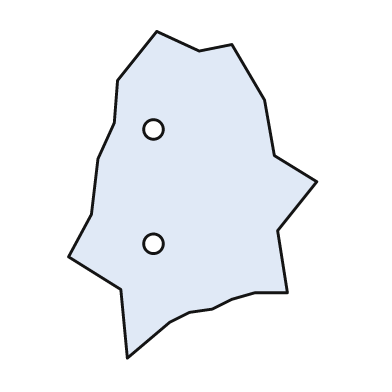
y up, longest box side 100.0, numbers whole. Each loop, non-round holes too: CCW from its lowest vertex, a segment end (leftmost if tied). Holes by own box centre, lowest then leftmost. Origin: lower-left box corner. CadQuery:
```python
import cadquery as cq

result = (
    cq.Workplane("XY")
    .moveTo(18.0, 0.0)
    .lineTo(31.0, 11.0)
    .lineTo(37.0, 14.0)
    .lineTo(44.0, 15.0)
    .lineTo(50.0, 18.0)
    .lineTo(57.0, 20.0)
    .lineTo(67.0, 20.0)
    .lineTo(64.0, 39.0)
    .lineTo(76.0, 54.0)
    .lineTo(63.0, 62.0)
    .lineTo(60.0, 79.0)
    .lineTo(50.0, 96.0)
    .lineTo(40.0, 94.0)
    .lineTo(27.0, 100.0)
    .lineTo(15.0, 85.0)
    .lineTo(14.0, 72.0)
    .lineTo(9.0, 61.0)
    .lineTo(7.0, 44.0)
    .lineTo(0.0, 31.0)
    .lineTo(16.0, 21.0)
    .close()
    .moveTo(26.0, 35.0)
    .circle(3.0)
    .moveTo(26.0, 70.0)
    .circle(3.0)
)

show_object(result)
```